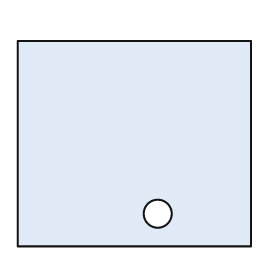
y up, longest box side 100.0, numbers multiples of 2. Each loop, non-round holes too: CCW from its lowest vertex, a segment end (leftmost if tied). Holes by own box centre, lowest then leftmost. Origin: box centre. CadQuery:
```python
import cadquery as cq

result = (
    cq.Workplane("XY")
    .moveTo(-50.0, -44.0)
    .lineTo(50.0, -44.0)
    .lineTo(50.0, 44.0)
    .lineTo(-50.0, 44.0)
    .close()
    .moveTo(10.0, -30.0)
    .circle(6.0)
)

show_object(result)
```